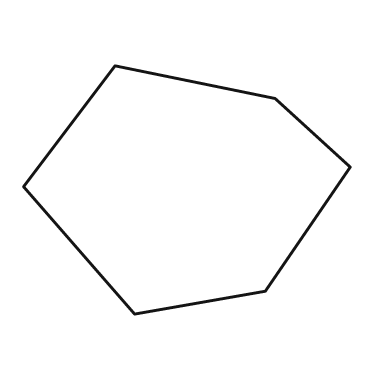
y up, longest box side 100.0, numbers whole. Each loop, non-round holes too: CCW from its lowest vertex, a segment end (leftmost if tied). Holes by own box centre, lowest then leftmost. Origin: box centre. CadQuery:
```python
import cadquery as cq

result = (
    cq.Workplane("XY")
    .moveTo(-16.0, -38.0)
    .lineTo(24.0, -31.0)
    .lineTo(50.0, 7.0)
    .lineTo(27.0, 28.0)
    .lineTo(-22.0, 38.0)
    .lineTo(-50.0, 1.0)
    .close()
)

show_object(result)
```